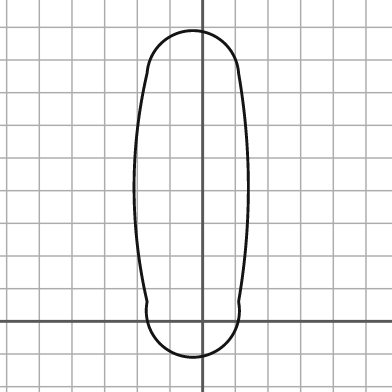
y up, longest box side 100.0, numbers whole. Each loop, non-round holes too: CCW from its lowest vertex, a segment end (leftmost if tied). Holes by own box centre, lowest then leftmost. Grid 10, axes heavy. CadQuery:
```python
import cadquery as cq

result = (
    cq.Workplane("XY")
    .moveTo(-17.0, 6.0)
    .threePointArc((-3.0, -11.0), (11.0, 6.0))
    .threePointArc((14.0, 41.0), (11.0, 76.0))
    .threePointArc((-3.0, 89.0), (-17.0, 76.0))
    .threePointArc((-21.0, 41.0), (-17.0, 6.0))
    .close()
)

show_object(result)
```